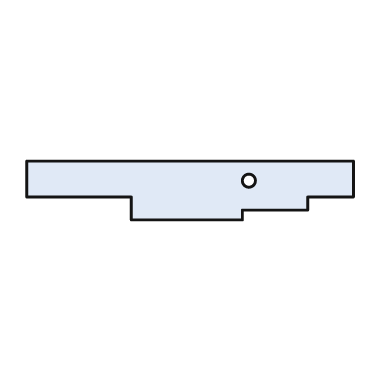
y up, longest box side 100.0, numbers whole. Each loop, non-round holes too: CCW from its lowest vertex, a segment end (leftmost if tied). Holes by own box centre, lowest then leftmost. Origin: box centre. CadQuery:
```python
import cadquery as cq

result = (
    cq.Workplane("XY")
    .moveTo(-18.0, -9.0)
    .lineTo(16.0, -9.0)
    .lineTo(16.0, -6.0)
    .lineTo(36.0, -6.0)
    .lineTo(36.0, -2.0)
    .lineTo(50.0, -2.0)
    .lineTo(50.0, 9.0)
    .lineTo(-50.0, 9.0)
    .lineTo(-50.0, -2.0)
    .lineTo(-18.0, -2.0)
    .close()
    .moveTo(18.0, 3.0)
    .circle(2.0)
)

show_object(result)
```